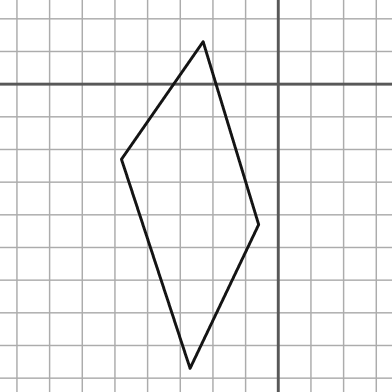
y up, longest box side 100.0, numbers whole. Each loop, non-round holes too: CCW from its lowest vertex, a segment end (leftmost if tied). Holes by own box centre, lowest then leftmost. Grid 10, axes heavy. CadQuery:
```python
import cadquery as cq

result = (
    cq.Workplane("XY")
    .moveTo(-27.0, -87.0)
    .lineTo(-6.0, -43.0)
    .lineTo(-23.0, 13.0)
    .lineTo(-48.0, -23.0)
    .close()
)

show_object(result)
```